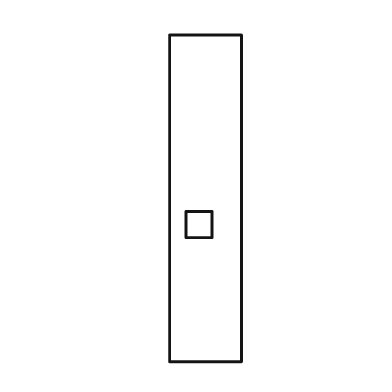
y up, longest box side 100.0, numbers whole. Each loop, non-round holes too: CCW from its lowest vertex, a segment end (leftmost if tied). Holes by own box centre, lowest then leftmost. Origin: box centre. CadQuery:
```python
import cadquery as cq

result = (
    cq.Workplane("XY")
    .moveTo(-11.0, -50.0)
    .lineTo(11.0, -50.0)
    .lineTo(11.0, 50.0)
    .lineTo(-11.0, 50.0)
    .close()
    .moveTo(-6.0, -12.0)
    .lineTo(2.0, -12.0)
    .lineTo(2.0, -4.0)
    .lineTo(-6.0, -4.0)
    .close()
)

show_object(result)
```